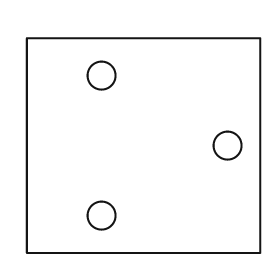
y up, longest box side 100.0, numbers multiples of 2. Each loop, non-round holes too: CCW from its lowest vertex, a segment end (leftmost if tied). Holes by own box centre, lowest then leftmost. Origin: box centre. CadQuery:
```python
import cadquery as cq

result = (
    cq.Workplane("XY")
    .moveTo(-50.0, -46.0)
    .lineTo(50.0, -46.0)
    .lineTo(50.0, 46.0)
    .lineTo(-50.0, 46.0)
    .close()
    .moveTo(-18.0, -30.0)
    .circle(6.0)
    .moveTo(36.0, 0.0)
    .circle(6.0)
    .moveTo(-18.0, 30.0)
    .circle(6.0)
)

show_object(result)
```